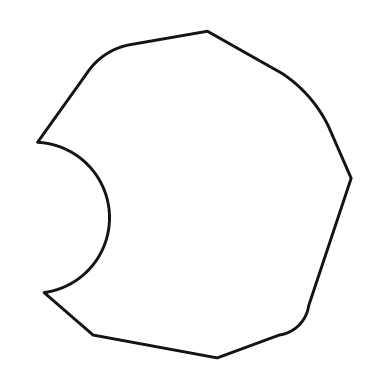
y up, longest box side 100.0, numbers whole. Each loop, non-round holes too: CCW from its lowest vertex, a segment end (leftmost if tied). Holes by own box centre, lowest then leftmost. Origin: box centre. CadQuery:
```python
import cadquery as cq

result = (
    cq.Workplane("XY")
    .moveTo(7.0, -50.0)
    .lineTo(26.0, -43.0)
    .threePointArc((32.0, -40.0), (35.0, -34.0))
    .lineTo(48.0, 5.0)
    .lineTo(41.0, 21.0)
    .threePointArc((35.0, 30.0), (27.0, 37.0))
    .lineTo(4.0, 50.0)
    .lineTo(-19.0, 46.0)
    .threePointArc((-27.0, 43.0), (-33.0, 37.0))
    .lineTo(-48.0, 16.0)
    .threePointArc((-26.0, -6.0), (-46.0, -30.0))
    .lineTo(-31.0, -43.0)
    .close()
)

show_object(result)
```